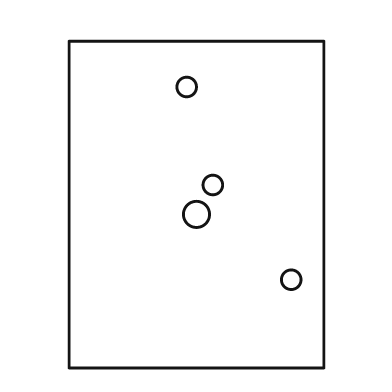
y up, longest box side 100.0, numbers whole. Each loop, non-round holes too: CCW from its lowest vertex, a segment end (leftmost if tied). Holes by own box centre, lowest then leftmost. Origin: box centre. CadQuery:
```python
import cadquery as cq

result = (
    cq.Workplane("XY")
    .moveTo(-39.0, -50.0)
    .lineTo(39.0, -50.0)
    .lineTo(39.0, 50.0)
    .lineTo(-39.0, 50.0)
    .close()
    .moveTo(29.0, -23.0)
    .circle(3.0)
    .moveTo(0.0, -3.0)
    .circle(4.0)
    .moveTo(5.0, 6.0)
    .circle(3.0)
    .moveTo(-3.0, 36.0)
    .circle(3.0)
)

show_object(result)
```